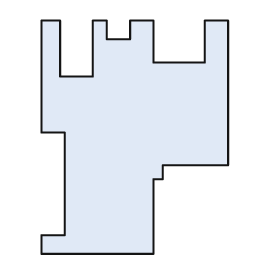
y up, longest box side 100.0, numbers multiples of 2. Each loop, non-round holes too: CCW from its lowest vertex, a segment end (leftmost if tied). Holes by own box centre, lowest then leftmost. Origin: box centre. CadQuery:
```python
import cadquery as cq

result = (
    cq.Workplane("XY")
    .moveTo(-40.0, -50.0)
    .lineTo(8.0, -50.0)
    .lineTo(8.0, -18.0)
    .lineTo(12.0, -18.0)
    .lineTo(12.0, -12.0)
    .lineTo(40.0, -12.0)
    .lineTo(40.0, 50.0)
    .lineTo(30.0, 50.0)
    .lineTo(30.0, 32.0)
    .lineTo(8.0, 32.0)
    .lineTo(8.0, 50.0)
    .lineTo(-2.0, 50.0)
    .lineTo(-2.0, 42.0)
    .lineTo(-12.0, 42.0)
    .lineTo(-12.0, 50.0)
    .lineTo(-18.0, 50.0)
    .lineTo(-18.0, 26.0)
    .lineTo(-32.0, 26.0)
    .lineTo(-32.0, 50.0)
    .lineTo(-40.0, 50.0)
    .lineTo(-40.0, 2.0)
    .lineTo(-30.0, 2.0)
    .lineTo(-30.0, -42.0)
    .lineTo(-40.0, -42.0)
    .close()
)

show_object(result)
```